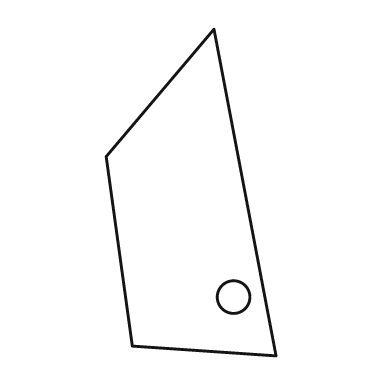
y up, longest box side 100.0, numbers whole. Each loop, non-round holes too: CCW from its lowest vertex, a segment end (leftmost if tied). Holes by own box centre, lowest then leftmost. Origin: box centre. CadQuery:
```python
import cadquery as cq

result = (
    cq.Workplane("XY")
    .moveTo(26.0, -50.0)
    .lineTo(7.0, 50.0)
    .lineTo(-26.0, 11.0)
    .lineTo(-18.0, -47.0)
    .close()
    .moveTo(13.0, -32.0)
    .circle(5.0)
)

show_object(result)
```